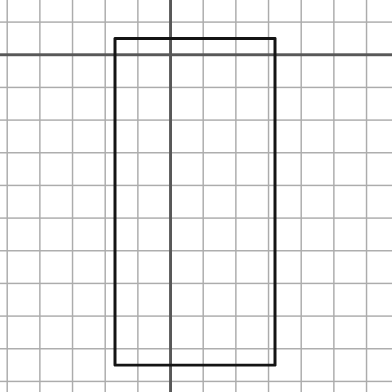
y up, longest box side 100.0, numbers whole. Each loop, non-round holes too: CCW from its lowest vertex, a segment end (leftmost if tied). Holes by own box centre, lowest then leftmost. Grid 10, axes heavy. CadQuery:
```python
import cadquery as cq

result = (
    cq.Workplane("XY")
    .moveTo(-17.0, -95.0)
    .lineTo(32.0, -95.0)
    .lineTo(32.0, 5.0)
    .lineTo(-17.0, 5.0)
    .close()
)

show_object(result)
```